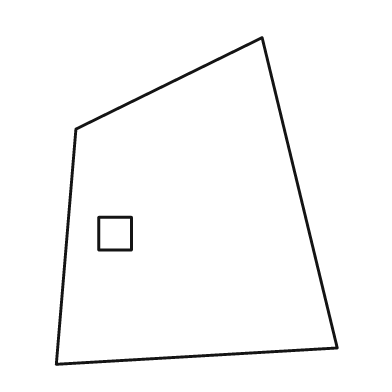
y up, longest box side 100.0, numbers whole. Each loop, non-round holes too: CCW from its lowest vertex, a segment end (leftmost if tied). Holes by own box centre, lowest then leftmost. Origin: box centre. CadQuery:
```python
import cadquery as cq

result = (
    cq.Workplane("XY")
    .moveTo(-43.0, -50.0)
    .lineTo(43.0, -45.0)
    .lineTo(20.0, 50.0)
    .lineTo(-37.0, 22.0)
    .close()
    .moveTo(-30.0, -15.0)
    .lineTo(-20.0, -15.0)
    .lineTo(-20.0, -5.0)
    .lineTo(-30.0, -5.0)
    .close()
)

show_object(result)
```